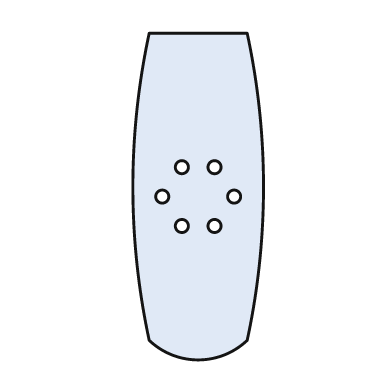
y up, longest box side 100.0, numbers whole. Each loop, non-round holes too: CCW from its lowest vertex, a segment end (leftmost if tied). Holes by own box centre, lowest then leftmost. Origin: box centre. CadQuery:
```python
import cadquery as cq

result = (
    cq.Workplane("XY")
    .moveTo(-15.0, -44.0)
    .threePointArc((0.0, -50.0), (15.0, -44.0))
    .threePointArc((20.0, 3.0), (15.0, 50.0))
    .lineTo(-15.0, 50.0)
    .threePointArc((-20.0, 3.0), (-15.0, -44.0))
    .close()
    .moveTo(-5.0, -9.0)
    .circle(2.0)
    .moveTo(5.0, -9.0)
    .circle(2.0)
    .moveTo(-11.0, 0.0)
    .circle(2.0)
    .moveTo(11.0, 0.0)
    .circle(2.0)
    .moveTo(-5.0, 9.0)
    .circle(2.0)
    .moveTo(5.0, 9.0)
    .circle(2.0)
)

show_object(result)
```